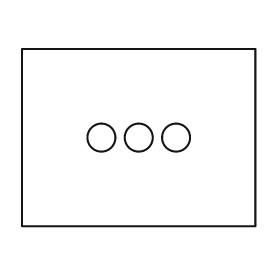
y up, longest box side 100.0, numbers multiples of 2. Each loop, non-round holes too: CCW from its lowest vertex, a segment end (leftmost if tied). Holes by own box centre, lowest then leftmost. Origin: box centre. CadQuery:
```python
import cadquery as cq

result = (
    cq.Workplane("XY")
    .moveTo(-50.0, -38.0)
    .lineTo(50.0, -38.0)
    .lineTo(50.0, 38.0)
    .lineTo(-50.0, 38.0)
    .close()
    .moveTo(-16.0, 0.0)
    .circle(6.0)
    .moveTo(0.0, 0.0)
    .circle(6.0)
    .moveTo(16.0, 0.0)
    .circle(6.0)
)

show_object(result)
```